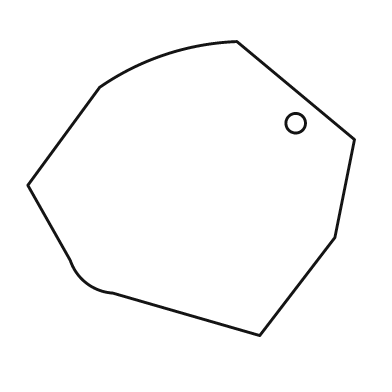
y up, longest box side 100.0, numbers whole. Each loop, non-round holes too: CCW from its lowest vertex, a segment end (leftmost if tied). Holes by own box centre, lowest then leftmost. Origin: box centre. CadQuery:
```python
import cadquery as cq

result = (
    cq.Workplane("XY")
    .moveTo(21.0, -45.0)
    .lineTo(44.0, -15.0)
    .lineTo(50.0, 15.0)
    .lineTo(14.0, 45.0)
    .threePointArc((-8.0, 41.0), (-28.0, 31.0))
    .lineTo(-50.0, 1.0)
    .lineTo(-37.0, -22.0)
    .threePointArc((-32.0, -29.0), (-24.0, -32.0))
    .close()
    .moveTo(32.0, 20.0)
    .circle(3.0)
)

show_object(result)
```